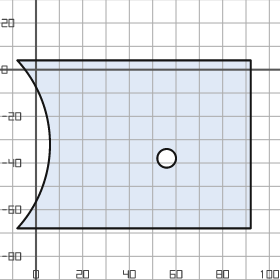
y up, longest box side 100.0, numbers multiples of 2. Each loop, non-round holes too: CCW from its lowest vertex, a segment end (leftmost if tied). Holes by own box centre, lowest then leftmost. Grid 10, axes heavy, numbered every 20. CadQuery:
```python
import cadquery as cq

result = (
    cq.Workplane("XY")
    .moveTo(-8.0, -68.0)
    .lineTo(92.0, -68.0)
    .lineTo(92.0, 4.0)
    .lineTo(-8.0, 4.0)
    .threePointArc((6.0, -32.0), (-8.0, -68.0))
    .close()
    .moveTo(56.0, -38.0)
    .circle(4.0)
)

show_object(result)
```